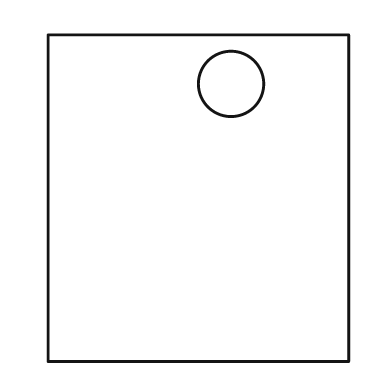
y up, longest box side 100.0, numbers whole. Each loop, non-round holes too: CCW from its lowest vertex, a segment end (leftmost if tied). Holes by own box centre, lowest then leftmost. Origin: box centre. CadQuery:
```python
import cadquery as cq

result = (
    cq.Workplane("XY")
    .moveTo(-46.0, -50.0)
    .lineTo(46.0, -50.0)
    .lineTo(46.0, 50.0)
    .lineTo(-46.0, 50.0)
    .close()
    .moveTo(10.0, 35.0)
    .circle(10.0)
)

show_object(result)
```